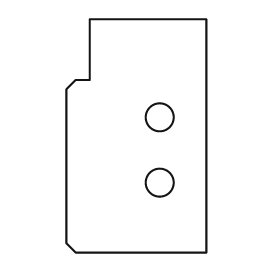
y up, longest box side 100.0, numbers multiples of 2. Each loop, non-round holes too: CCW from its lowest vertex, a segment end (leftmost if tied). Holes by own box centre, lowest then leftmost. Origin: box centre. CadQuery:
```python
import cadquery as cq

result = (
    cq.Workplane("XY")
    .moveTo(-26.0, -50.0)
    .lineTo(30.0, -50.0)
    .lineTo(30.0, 50.0)
    .lineTo(-20.0, 50.0)
    .lineTo(-20.0, 24.0)
    .lineTo(-26.0, 24.0)
    .lineTo(-30.0, 20.0)
    .lineTo(-30.0, -46.0)
    .close()
    .moveTo(10.0, -20.0)
    .circle(6.0)
    .moveTo(10.0, 8.0)
    .circle(6.0)
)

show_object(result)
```